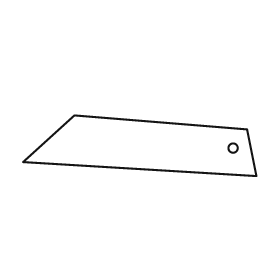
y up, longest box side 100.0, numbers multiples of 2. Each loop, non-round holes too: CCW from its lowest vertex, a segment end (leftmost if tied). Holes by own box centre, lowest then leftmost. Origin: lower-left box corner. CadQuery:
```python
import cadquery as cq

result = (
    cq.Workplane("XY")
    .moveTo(100.0, 0.0)
    .lineTo(96.0, 20.0)
    .lineTo(22.0, 26.0)
    .lineTo(0.0, 6.0)
    .close()
    .moveTo(90.0, 12.0)
    .circle(2.0)
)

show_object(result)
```